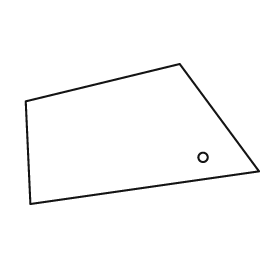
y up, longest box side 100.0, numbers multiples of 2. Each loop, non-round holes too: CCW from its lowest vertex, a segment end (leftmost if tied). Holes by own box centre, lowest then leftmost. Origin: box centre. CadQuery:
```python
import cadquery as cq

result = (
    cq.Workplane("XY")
    .moveTo(-48.0, -30.0)
    .lineTo(50.0, -16.0)
    .lineTo(16.0, 30.0)
    .lineTo(-50.0, 14.0)
    .close()
    .moveTo(26.0, -10.0)
    .circle(2.0)
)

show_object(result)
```